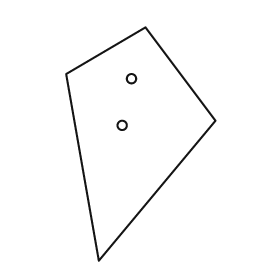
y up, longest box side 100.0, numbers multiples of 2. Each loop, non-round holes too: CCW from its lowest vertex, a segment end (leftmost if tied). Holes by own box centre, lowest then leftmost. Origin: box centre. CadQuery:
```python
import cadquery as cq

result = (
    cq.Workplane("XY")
    .moveTo(-18.0, -50.0)
    .lineTo(32.0, 10.0)
    .lineTo(2.0, 50.0)
    .lineTo(-32.0, 30.0)
    .close()
    .moveTo(-8.0, 8.0)
    .circle(2.0)
    .moveTo(-4.0, 28.0)
    .circle(2.0)
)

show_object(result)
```